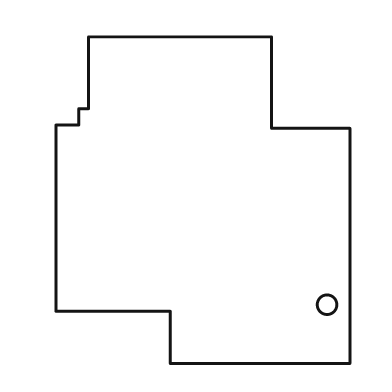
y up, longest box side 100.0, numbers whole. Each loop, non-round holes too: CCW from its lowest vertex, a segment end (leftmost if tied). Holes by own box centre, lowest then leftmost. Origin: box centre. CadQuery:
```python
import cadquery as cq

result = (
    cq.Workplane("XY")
    .moveTo(-10.0, -50.0)
    .lineTo(45.0, -50.0)
    .lineTo(45.0, 22.0)
    .lineTo(21.0, 22.0)
    .lineTo(21.0, 50.0)
    .lineTo(-35.0, 50.0)
    .lineTo(-35.0, 28.0)
    .lineTo(-38.0, 28.0)
    .lineTo(-38.0, 23.0)
    .lineTo(-45.0, 23.0)
    .lineTo(-45.0, -34.0)
    .lineTo(-10.0, -34.0)
    .close()
    .moveTo(38.0, -32.0)
    .circle(3.0)
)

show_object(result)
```